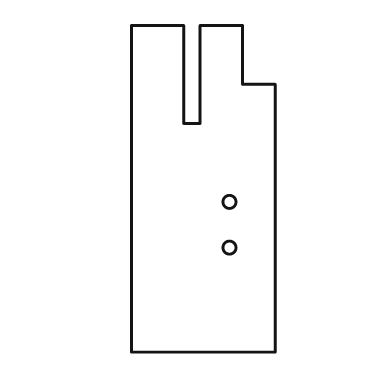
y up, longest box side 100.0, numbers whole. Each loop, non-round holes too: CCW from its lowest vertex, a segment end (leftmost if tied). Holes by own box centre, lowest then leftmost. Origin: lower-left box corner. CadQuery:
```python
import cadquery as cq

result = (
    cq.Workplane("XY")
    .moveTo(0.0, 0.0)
    .lineTo(44.0, 0.0)
    .lineTo(44.0, 82.0)
    .lineTo(34.0, 82.0)
    .lineTo(34.0, 100.0)
    .lineTo(21.0, 100.0)
    .lineTo(21.0, 70.0)
    .lineTo(16.0, 70.0)
    .lineTo(16.0, 100.0)
    .lineTo(0.0, 100.0)
    .close()
    .moveTo(30.0, 32.0)
    .circle(2.0)
    .moveTo(30.0, 46.0)
    .circle(2.0)
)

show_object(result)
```